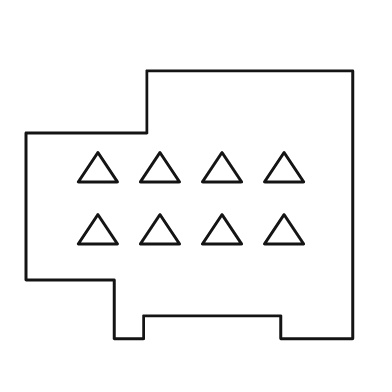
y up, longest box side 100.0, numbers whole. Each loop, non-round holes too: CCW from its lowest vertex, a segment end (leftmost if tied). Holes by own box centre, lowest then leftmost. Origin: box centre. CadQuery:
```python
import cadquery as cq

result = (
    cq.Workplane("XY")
    .moveTo(-23.0, -41.0)
    .lineTo(-14.0, -41.0)
    .lineTo(-14.0, -34.0)
    .lineTo(28.0, -34.0)
    .lineTo(28.0, -41.0)
    .lineTo(50.0, -41.0)
    .lineTo(50.0, 41.0)
    .lineTo(-13.0, 41.0)
    .lineTo(-13.0, 22.0)
    .lineTo(-50.0, 22.0)
    .lineTo(-50.0, -23.0)
    .lineTo(-23.0, -23.0)
    .close()
    .moveTo(-34.0, -12.0)
    .lineTo(-22.0, -12.0)
    .lineTo(-28.0, -3.0)
    .close()
    .moveTo(-15.0, -12.0)
    .lineTo(-3.0, -12.0)
    .lineTo(-9.0, -3.0)
    .close()
    .moveTo(4.0, -12.0)
    .lineTo(16.0, -12.0)
    .lineTo(10.0, -3.0)
    .close()
    .moveTo(23.0, -12.0)
    .lineTo(35.0, -12.0)
    .lineTo(29.0, -3.0)
    .close()
    .moveTo(-34.0, 7.0)
    .lineTo(-22.0, 7.0)
    .lineTo(-28.0, 16.0)
    .close()
    .moveTo(-15.0, 7.0)
    .lineTo(-3.0, 7.0)
    .lineTo(-9.0, 16.0)
    .close()
    .moveTo(4.0, 7.0)
    .lineTo(16.0, 7.0)
    .lineTo(10.0, 16.0)
    .close()
    .moveTo(23.0, 7.0)
    .lineTo(35.0, 7.0)
    .lineTo(29.0, 16.0)
    .close()
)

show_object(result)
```